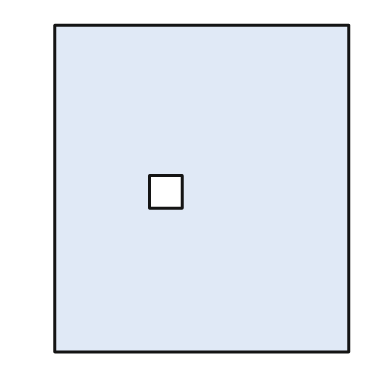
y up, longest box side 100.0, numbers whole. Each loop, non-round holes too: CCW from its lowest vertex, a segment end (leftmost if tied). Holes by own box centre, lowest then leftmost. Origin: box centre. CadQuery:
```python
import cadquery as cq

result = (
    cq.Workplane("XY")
    .moveTo(-45.0, -50.0)
    .lineTo(45.0, -50.0)
    .lineTo(45.0, 50.0)
    .lineTo(-45.0, 50.0)
    .close()
    .moveTo(-16.0, -6.0)
    .lineTo(-6.0, -6.0)
    .lineTo(-6.0, 4.0)
    .lineTo(-16.0, 4.0)
    .close()
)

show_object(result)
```